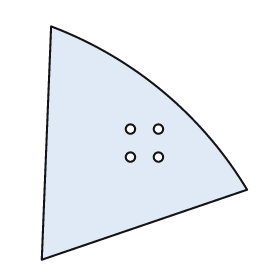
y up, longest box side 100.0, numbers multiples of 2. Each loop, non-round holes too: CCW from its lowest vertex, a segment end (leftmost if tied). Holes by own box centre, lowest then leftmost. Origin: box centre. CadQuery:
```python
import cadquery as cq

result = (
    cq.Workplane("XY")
    .moveTo(-44.0, -50.0)
    .lineTo(44.0, -20.0)
    .threePointArc((8.0, 22.0), (-40.0, 50.0))
    .close()
    .moveTo(-6.0, -6.0)
    .circle(2.0)
    .moveTo(6.0, -6.0)
    .circle(2.0)
    .moveTo(-6.0, 6.0)
    .circle(2.0)
    .moveTo(6.0, 6.0)
    .circle(2.0)
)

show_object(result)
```